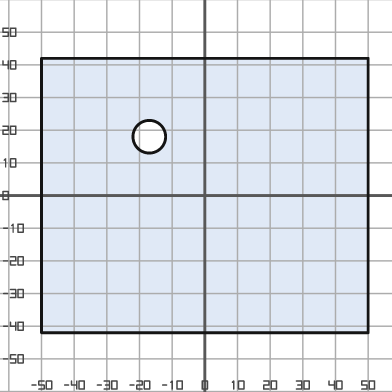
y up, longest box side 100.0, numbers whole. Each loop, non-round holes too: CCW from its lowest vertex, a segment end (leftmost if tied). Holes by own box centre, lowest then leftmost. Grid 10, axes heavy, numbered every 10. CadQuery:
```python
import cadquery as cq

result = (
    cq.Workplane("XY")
    .moveTo(-50.0, -42.0)
    .lineTo(50.0, -42.0)
    .lineTo(50.0, 42.0)
    .lineTo(-50.0, 42.0)
    .close()
    .moveTo(-17.0, 18.0)
    .circle(5.0)
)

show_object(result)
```